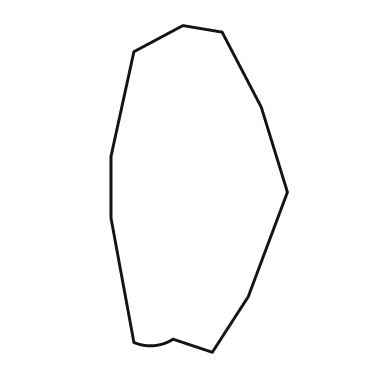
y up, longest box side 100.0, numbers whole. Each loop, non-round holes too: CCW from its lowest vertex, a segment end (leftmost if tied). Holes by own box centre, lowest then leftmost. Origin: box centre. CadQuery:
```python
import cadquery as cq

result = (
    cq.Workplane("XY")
    .moveTo(4.0, -50.0)
    .lineTo(15.0, -33.0)
    .lineTo(27.0, -1.0)
    .lineTo(19.0, 25.0)
    .lineTo(7.0, 48.0)
    .lineTo(-5.0, 50.0)
    .lineTo(-20.0, 42.0)
    .lineTo(-27.0, 10.0)
    .lineTo(-27.0, -9.0)
    .lineTo(-20.0, -47.0)
    .threePointArc((-14.0, -48.0), (-8.0, -46.0))
    .close()
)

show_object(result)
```